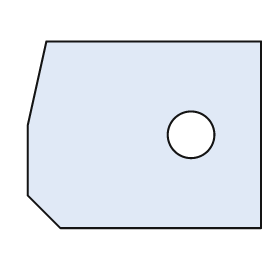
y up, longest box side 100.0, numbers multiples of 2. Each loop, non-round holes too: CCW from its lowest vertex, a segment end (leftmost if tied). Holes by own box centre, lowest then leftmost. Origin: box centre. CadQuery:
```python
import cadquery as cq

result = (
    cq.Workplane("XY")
    .moveTo(-36.0, -40.0)
    .lineTo(50.0, -40.0)
    .lineTo(50.0, 40.0)
    .lineTo(-42.0, 40.0)
    .lineTo(-50.0, 4.0)
    .lineTo(-50.0, -26.0)
    .close()
    .moveTo(20.0, 0.0)
    .circle(10.0)
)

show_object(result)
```